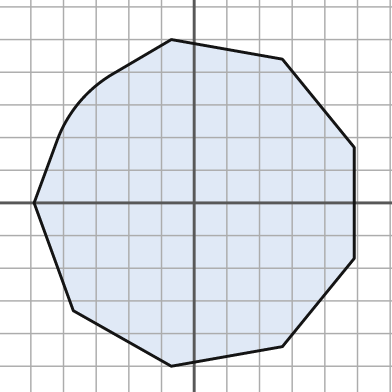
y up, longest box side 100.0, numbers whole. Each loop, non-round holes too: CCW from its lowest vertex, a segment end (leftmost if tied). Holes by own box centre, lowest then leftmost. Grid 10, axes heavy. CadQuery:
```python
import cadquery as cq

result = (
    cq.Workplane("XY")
    .moveTo(-7.0, -50.0)
    .lineTo(27.0, -44.0)
    .lineTo(49.0, -17.0)
    .lineTo(49.0, 17.0)
    .lineTo(27.0, 44.0)
    .lineTo(-7.0, 50.0)
    .lineTo(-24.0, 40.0)
    .threePointArc((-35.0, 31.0), (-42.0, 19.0))
    .lineTo(-49.0, 0.0)
    .lineTo(-37.0, -33.0)
    .close()
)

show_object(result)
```